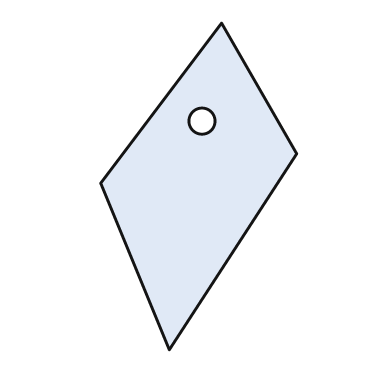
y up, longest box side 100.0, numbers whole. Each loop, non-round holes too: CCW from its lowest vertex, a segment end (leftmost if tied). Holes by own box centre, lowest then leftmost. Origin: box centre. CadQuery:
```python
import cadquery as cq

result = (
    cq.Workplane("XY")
    .moveTo(-9.0, -50.0)
    .lineTo(30.0, 10.0)
    .lineTo(7.0, 50.0)
    .lineTo(-30.0, 1.0)
    .close()
    .moveTo(1.0, 20.0)
    .circle(4.0)
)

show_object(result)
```